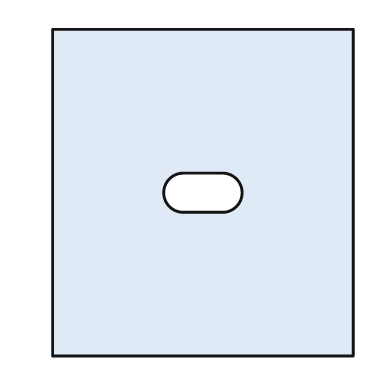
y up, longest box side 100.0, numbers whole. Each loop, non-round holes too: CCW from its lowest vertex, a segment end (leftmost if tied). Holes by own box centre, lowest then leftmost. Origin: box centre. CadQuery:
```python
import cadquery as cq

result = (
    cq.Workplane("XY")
    .moveTo(-46.0, -50.0)
    .lineTo(46.0, -50.0)
    .lineTo(46.0, 50.0)
    .lineTo(-46.0, 50.0)
    .close()
    .moveTo(-6.0, -6.0)
    .lineTo(6.0, -6.0)
    .threePointArc((12.0, 0.0), (6.0, 6.0))
    .lineTo(-6.0, 6.0)
    .threePointArc((-12.0, 0.0), (-6.0, -6.0))
    .close()
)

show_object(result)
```